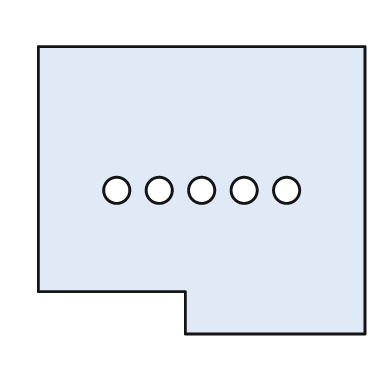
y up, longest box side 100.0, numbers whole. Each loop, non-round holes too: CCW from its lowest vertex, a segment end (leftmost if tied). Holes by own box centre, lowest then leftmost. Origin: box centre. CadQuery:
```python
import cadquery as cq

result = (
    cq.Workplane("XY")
    .moveTo(-5.0, -44.0)
    .lineTo(50.0, -44.0)
    .lineTo(50.0, 44.0)
    .lineTo(-50.0, 44.0)
    .lineTo(-50.0, -31.0)
    .lineTo(-5.0, -31.0)
    .close()
    .moveTo(-26.0, 0.0)
    .circle(4.0)
    .moveTo(-13.0, 0.0)
    .circle(4.0)
    .moveTo(0.0, 0.0)
    .circle(4.0)
    .moveTo(13.0, 0.0)
    .circle(4.0)
    .moveTo(26.0, 0.0)
    .circle(4.0)
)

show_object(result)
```